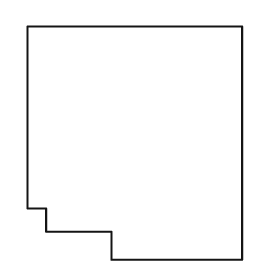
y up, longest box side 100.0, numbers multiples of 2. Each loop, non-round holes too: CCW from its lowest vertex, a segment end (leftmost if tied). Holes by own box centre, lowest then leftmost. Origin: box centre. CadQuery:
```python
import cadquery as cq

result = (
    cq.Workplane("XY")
    .moveTo(-10.0, -50.0)
    .lineTo(46.0, -50.0)
    .lineTo(46.0, 50.0)
    .lineTo(-46.0, 50.0)
    .lineTo(-46.0, -28.0)
    .lineTo(-38.0, -28.0)
    .lineTo(-38.0, -38.0)
    .lineTo(-10.0, -38.0)
    .close()
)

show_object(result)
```